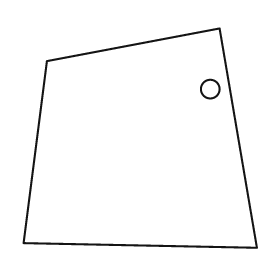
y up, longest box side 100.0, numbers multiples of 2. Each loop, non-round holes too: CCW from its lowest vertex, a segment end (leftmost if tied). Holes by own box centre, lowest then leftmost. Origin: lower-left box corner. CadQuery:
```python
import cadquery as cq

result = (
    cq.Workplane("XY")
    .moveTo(100.0, 0.0)
    .lineTo(84.0, 94.0)
    .lineTo(10.0, 80.0)
    .lineTo(0.0, 2.0)
    .close()
    .moveTo(80.0, 68.0)
    .circle(4.0)
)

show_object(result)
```